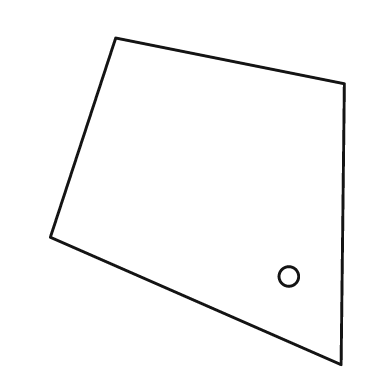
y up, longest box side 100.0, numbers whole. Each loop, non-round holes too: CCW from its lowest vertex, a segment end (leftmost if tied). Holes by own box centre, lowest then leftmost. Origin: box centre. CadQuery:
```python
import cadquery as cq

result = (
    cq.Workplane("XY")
    .moveTo(44.0, -50.0)
    .lineTo(45.0, 36.0)
    .lineTo(-25.0, 50.0)
    .lineTo(-45.0, -11.0)
    .close()
    .moveTo(28.0, -23.0)
    .circle(3.0)
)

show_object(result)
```